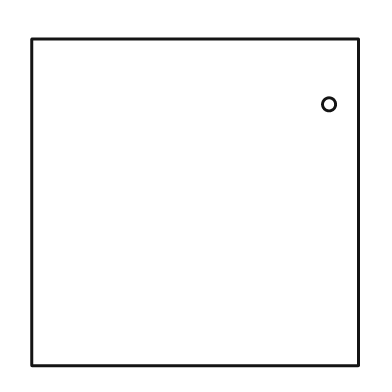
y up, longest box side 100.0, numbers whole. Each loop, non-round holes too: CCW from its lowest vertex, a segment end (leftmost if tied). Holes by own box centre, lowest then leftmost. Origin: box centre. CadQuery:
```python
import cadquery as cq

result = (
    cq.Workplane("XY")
    .moveTo(-50.0, -50.0)
    .lineTo(50.0, -50.0)
    .lineTo(50.0, 50.0)
    .lineTo(-50.0, 50.0)
    .close()
    .moveTo(41.0, 30.0)
    .circle(2.0)
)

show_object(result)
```